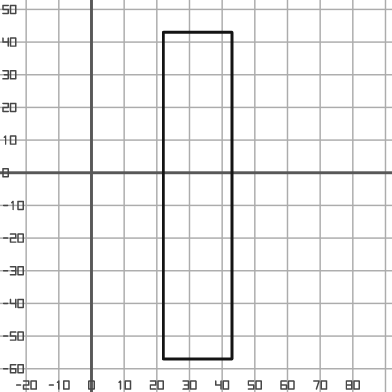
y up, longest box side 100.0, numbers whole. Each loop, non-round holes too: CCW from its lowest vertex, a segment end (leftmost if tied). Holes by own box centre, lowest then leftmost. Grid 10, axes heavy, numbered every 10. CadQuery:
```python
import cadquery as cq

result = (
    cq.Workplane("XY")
    .moveTo(22.0, -57.0)
    .lineTo(43.0, -57.0)
    .lineTo(43.0, 43.0)
    .lineTo(22.0, 43.0)
    .close()
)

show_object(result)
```